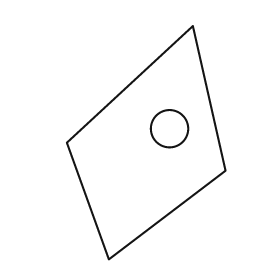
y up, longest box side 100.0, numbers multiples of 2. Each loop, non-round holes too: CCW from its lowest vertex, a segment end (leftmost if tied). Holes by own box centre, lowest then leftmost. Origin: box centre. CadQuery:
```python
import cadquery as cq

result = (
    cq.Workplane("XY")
    .moveTo(-16.0, -50.0)
    .lineTo(34.0, -12.0)
    .lineTo(20.0, 50.0)
    .lineTo(-34.0, 0.0)
    .close()
    .moveTo(10.0, 6.0)
    .circle(8.0)
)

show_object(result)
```